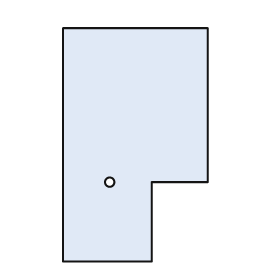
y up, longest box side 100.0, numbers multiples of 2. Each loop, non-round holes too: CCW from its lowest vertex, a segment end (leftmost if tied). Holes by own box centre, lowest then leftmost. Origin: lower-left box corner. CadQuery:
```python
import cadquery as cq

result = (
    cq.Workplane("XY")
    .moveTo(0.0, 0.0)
    .lineTo(38.0, 0.0)
    .lineTo(38.0, 34.0)
    .lineTo(62.0, 34.0)
    .lineTo(62.0, 100.0)
    .lineTo(0.0, 100.0)
    .close()
    .moveTo(20.0, 34.0)
    .circle(2.0)
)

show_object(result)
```